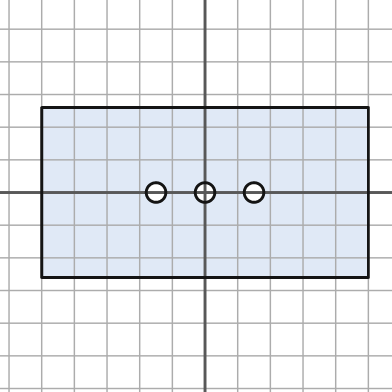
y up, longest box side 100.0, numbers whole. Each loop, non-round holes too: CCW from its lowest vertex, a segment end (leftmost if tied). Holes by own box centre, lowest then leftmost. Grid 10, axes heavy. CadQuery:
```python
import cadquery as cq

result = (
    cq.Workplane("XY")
    .moveTo(-50.0, -26.0)
    .lineTo(50.0, -26.0)
    .lineTo(50.0, 26.0)
    .lineTo(-50.0, 26.0)
    .close()
    .moveTo(-15.0, 0.0)
    .circle(3.0)
    .moveTo(0.0, 0.0)
    .circle(3.0)
    .moveTo(15.0, 0.0)
    .circle(3.0)
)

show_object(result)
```